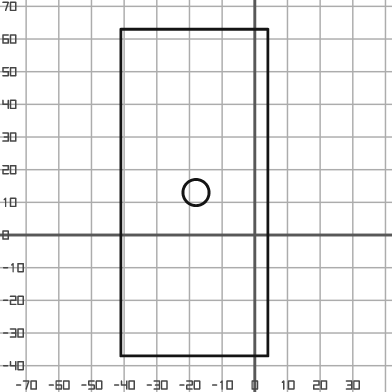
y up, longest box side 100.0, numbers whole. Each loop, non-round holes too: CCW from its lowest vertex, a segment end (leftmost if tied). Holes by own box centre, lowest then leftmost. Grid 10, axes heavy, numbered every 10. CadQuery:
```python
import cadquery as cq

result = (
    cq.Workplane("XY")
    .moveTo(-41.0, -37.0)
    .lineTo(4.0, -37.0)
    .lineTo(4.0, 63.0)
    .lineTo(-41.0, 63.0)
    .close()
    .moveTo(-18.0, 13.0)
    .circle(4.0)
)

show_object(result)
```